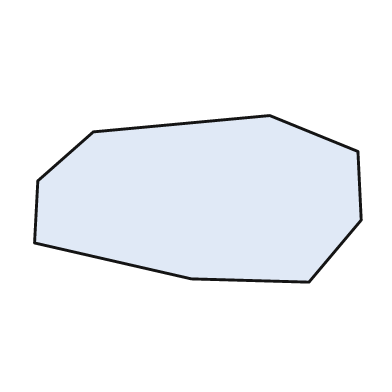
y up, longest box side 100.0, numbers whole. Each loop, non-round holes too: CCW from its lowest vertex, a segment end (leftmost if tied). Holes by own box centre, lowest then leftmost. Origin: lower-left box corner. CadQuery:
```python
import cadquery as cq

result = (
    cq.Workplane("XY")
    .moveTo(84.0, 0.0)
    .lineTo(100.0, 19.0)
    .lineTo(99.0, 40.0)
    .lineTo(72.0, 51.0)
    .lineTo(18.0, 46.0)
    .lineTo(1.0, 31.0)
    .lineTo(0.0, 12.0)
    .lineTo(48.0, 1.0)
    .close()
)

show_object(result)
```